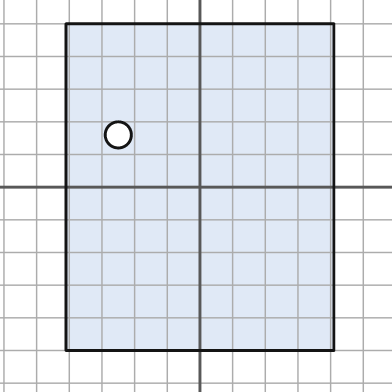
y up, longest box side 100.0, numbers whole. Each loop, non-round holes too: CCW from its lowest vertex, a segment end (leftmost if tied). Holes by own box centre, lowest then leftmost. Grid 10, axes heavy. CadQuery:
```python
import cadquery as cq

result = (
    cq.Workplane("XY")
    .moveTo(-41.0, -50.0)
    .lineTo(41.0, -50.0)
    .lineTo(41.0, 50.0)
    .lineTo(-41.0, 50.0)
    .close()
    .moveTo(-25.0, 16.0)
    .circle(4.0)
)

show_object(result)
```